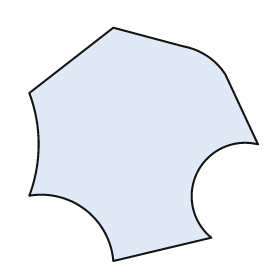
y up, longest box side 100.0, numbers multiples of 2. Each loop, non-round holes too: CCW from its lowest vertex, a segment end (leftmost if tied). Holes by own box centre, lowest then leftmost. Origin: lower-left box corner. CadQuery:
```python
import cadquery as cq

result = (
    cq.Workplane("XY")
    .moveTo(36.0, 0.0)
    .lineTo(78.0, 10.0)
    .threePointArc((72.0, 38.0), (98.0, 50.0))
    .lineTo(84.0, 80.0)
    .threePointArc((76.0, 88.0), (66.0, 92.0))
    .lineTo(36.0, 100.0)
    .lineTo(0.0, 72.0)
    .threePointArc((4.0, 50.0), (0.0, 28.0))
    .threePointArc((24.0, 22.0), (36.0, 0.0))
    .close()
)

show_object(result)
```